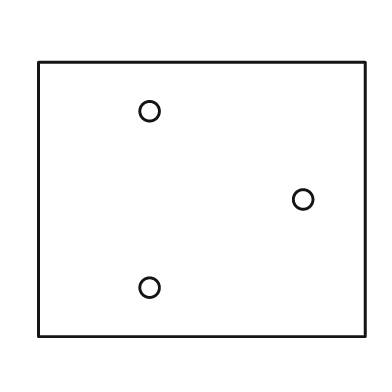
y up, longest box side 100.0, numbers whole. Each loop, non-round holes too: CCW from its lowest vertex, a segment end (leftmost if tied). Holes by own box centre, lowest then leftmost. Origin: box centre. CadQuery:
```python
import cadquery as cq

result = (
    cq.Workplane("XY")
    .moveTo(-50.0, -42.0)
    .lineTo(50.0, -42.0)
    .lineTo(50.0, 42.0)
    .lineTo(-50.0, 42.0)
    .close()
    .moveTo(-16.0, -27.0)
    .circle(3.0)
    .moveTo(31.0, 0.0)
    .circle(3.0)
    .moveTo(-16.0, 27.0)
    .circle(3.0)
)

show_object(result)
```